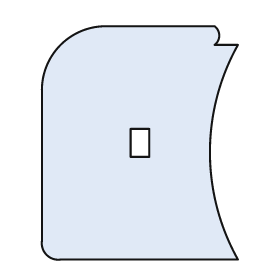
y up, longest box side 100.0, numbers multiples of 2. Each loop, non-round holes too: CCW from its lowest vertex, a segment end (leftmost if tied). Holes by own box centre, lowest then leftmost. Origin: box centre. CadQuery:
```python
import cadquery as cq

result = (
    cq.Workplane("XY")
    .moveTo(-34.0, -50.0)
    .lineTo(42.0, -50.0)
    .threePointArc((30.0, -4.0), (42.0, 42.0))
    .lineTo(32.0, 42.0)
    .threePointArc((34.0, 46.0), (32.0, 50.0))
    .lineTo(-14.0, 50.0)
    .threePointArc((-34.0, 42.0), (-42.0, 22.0))
    .lineTo(-42.0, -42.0)
    .threePointArc((-40.0, -48.0), (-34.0, -50.0))
    .close()
    .moveTo(-4.0, -6.0)
    .lineTo(4.0, -6.0)
    .lineTo(4.0, 6.0)
    .lineTo(-4.0, 6.0)
    .close()
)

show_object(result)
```